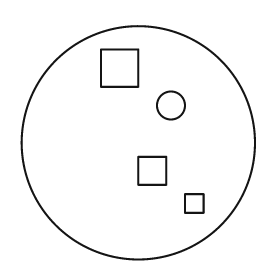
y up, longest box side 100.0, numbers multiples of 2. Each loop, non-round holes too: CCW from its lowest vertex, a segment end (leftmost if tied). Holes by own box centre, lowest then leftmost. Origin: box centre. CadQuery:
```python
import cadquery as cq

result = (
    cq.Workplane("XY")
    .moveTo(0.0, 0.0)
    .circle(50.0)
    .moveTo(20.0, -30.0)
    .lineTo(28.0, -30.0)
    .lineTo(28.0, -22.0)
    .lineTo(20.0, -22.0)
    .close()
    .moveTo(0.0, -18.0)
    .lineTo(12.0, -18.0)
    .lineTo(12.0, -6.0)
    .lineTo(0.0, -6.0)
    .close()
    .moveTo(14.0, 16.0)
    .circle(6.0)
    .moveTo(-16.0, 24.0)
    .lineTo(0.0, 24.0)
    .lineTo(0.0, 40.0)
    .lineTo(-16.0, 40.0)
    .close()
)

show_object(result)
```